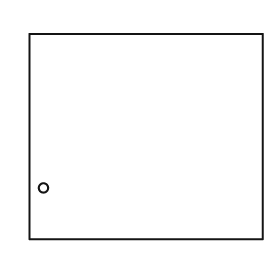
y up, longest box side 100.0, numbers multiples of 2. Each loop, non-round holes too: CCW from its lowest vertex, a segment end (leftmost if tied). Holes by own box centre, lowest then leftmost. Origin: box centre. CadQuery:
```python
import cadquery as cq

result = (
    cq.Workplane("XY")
    .moveTo(-50.0, -44.0)
    .lineTo(50.0, -44.0)
    .lineTo(50.0, 44.0)
    .lineTo(-50.0, 44.0)
    .close()
    .moveTo(-44.0, -22.0)
    .circle(2.0)
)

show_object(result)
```